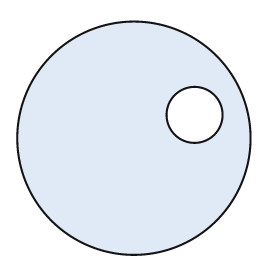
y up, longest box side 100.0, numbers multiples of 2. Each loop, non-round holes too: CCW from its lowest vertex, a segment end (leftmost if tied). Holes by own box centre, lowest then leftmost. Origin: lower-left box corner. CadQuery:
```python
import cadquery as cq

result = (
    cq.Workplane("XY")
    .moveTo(50.0, 50.0)
    .circle(50.0)
    .moveTo(76.0, 60.0)
    .circle(12.0)
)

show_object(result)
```